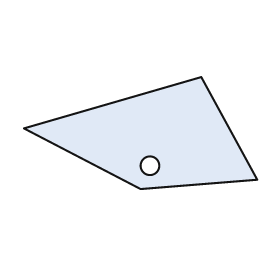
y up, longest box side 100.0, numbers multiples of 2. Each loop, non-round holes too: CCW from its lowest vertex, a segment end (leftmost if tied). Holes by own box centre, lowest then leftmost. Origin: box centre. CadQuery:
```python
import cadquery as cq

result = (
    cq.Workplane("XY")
    .moveTo(0.0, -24.0)
    .lineTo(50.0, -20.0)
    .lineTo(26.0, 24.0)
    .lineTo(-50.0, 2.0)
    .close()
    .moveTo(4.0, -14.0)
    .circle(4.0)
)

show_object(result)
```